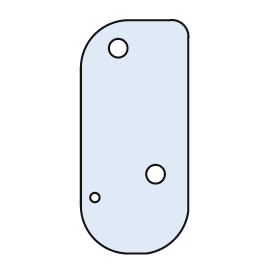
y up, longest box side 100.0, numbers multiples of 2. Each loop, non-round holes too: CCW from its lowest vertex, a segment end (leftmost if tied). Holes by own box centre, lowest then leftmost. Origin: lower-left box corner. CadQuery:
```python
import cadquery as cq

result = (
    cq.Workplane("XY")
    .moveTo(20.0, 0.0)
    .lineTo(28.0, 0.0)
    .threePointArc((40.0, 6.0), (46.0, 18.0))
    .lineTo(46.0, 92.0)
    .threePointArc((44.0, 98.0), (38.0, 100.0))
    .lineTo(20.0, 100.0)
    .threePointArc((6.0, 94.0), (0.0, 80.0))
    .lineTo(0.0, 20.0)
    .threePointArc((6.0, 6.0), (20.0, 0.0))
    .close()
    .moveTo(6.0, 24.0)
    .circle(2.0)
    .moveTo(32.0, 34.0)
    .circle(4.0)
    .moveTo(16.0, 88.0)
    .circle(4.0)
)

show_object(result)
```